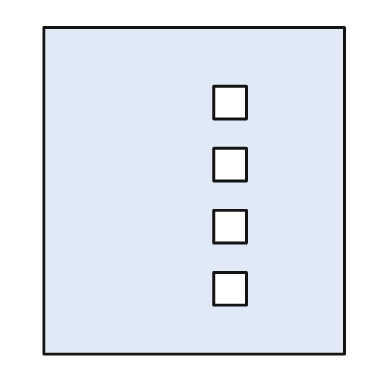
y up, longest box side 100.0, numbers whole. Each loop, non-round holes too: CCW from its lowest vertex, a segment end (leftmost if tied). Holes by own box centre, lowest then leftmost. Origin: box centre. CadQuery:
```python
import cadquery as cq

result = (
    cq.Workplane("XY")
    .moveTo(-46.0, -50.0)
    .lineTo(46.0, -50.0)
    .lineTo(46.0, 50.0)
    .lineTo(-46.0, 50.0)
    .close()
    .moveTo(6.0, -35.0)
    .lineTo(16.0, -35.0)
    .lineTo(16.0, -25.0)
    .lineTo(6.0, -25.0)
    .close()
    .moveTo(6.0, -16.0)
    .lineTo(16.0, -16.0)
    .lineTo(16.0, -6.0)
    .lineTo(6.0, -6.0)
    .close()
    .moveTo(6.0, 3.0)
    .lineTo(16.0, 3.0)
    .lineTo(16.0, 13.0)
    .lineTo(6.0, 13.0)
    .close()
    .moveTo(6.0, 22.0)
    .lineTo(16.0, 22.0)
    .lineTo(16.0, 32.0)
    .lineTo(6.0, 32.0)
    .close()
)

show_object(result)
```